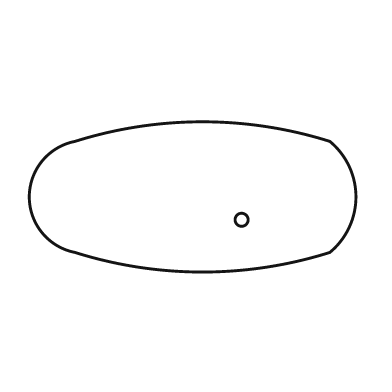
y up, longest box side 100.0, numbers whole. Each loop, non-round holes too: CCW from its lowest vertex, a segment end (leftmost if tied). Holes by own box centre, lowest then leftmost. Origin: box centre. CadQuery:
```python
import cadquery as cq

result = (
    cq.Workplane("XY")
    .moveTo(-36.0, -17.0)
    .threePointArc((3.0, -23.0), (42.0, -17.0))
    .threePointArc((50.0, 0.0), (42.0, 17.0))
    .threePointArc((3.0, 23.0), (-36.0, 17.0))
    .threePointArc((-50.0, 0.0), (-36.0, -17.0))
    .close()
    .moveTo(15.0, -7.0)
    .circle(2.0)
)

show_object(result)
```